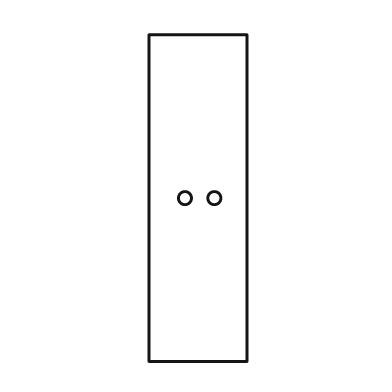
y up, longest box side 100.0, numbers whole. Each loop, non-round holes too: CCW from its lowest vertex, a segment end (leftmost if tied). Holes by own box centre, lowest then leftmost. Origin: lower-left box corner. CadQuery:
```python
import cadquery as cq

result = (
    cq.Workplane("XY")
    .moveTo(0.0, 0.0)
    .lineTo(30.0, 0.0)
    .lineTo(30.0, 100.0)
    .lineTo(0.0, 100.0)
    .close()
    .moveTo(11.0, 50.0)
    .circle(2.0)
    .moveTo(20.0, 50.0)
    .circle(2.0)
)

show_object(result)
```